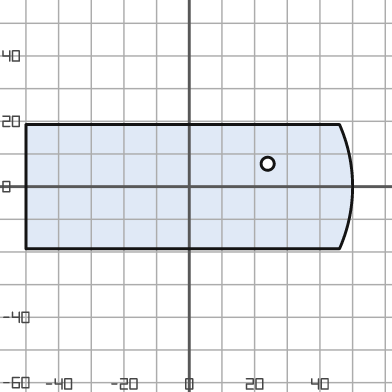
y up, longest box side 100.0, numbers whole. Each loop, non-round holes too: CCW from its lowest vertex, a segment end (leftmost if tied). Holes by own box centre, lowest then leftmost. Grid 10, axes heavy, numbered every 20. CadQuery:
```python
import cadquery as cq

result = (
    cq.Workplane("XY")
    .moveTo(-50.0, -19.0)
    .lineTo(46.0, -19.0)
    .threePointArc((50.0, 0.0), (46.0, 19.0))
    .lineTo(-50.0, 19.0)
    .close()
    .moveTo(24.0, 7.0)
    .circle(2.0)
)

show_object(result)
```